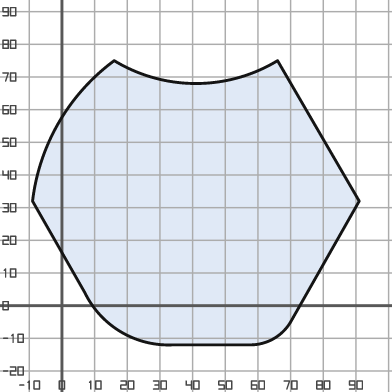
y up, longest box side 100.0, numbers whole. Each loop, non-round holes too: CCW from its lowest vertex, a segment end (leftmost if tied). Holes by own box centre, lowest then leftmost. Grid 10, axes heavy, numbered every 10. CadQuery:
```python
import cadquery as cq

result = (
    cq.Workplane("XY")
    .moveTo(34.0, -12.0)
    .lineTo(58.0, -12.0)
    .threePointArc((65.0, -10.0), (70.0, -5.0))
    .lineTo(91.0, 32.0)
    .lineTo(66.0, 75.0)
    .threePointArc((41.0, 68.0), (16.0, 75.0))
    .threePointArc((-1.0, 56.0), (-9.0, 32.0))
    .lineTo(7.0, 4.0)
    .threePointArc((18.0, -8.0), (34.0, -12.0))
    .close()
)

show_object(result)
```